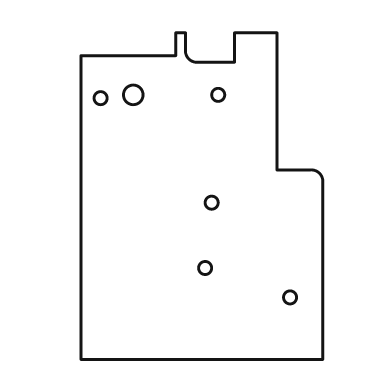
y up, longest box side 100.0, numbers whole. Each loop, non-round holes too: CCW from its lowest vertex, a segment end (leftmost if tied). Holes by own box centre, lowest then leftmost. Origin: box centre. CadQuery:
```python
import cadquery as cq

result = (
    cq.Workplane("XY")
    .moveTo(-37.0, -50.0)
    .lineTo(37.0, -50.0)
    .lineTo(37.0, 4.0)
    .threePointArc((36.0, 7.0), (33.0, 8.0))
    .lineTo(23.0, 8.0)
    .lineTo(23.0, 50.0)
    .lineTo(10.0, 50.0)
    .lineTo(10.0, 41.0)
    .lineTo(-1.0, 41.0)
    .threePointArc((-4.0, 42.0), (-5.0, 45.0))
    .lineTo(-5.0, 50.0)
    .lineTo(-8.0, 50.0)
    .lineTo(-8.0, 43.0)
    .lineTo(-37.0, 43.0)
    .close()
    .moveTo(27.0, -31.0)
    .circle(2.0)
    .moveTo(1.0, -22.0)
    .circle(2.0)
    .moveTo(3.0, -2.0)
    .circle(2.0)
    .moveTo(-31.0, 30.0)
    .circle(2.0)
    .moveTo(-21.0, 31.0)
    .circle(3.0)
    .moveTo(5.0, 31.0)
    .circle(2.0)
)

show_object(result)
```